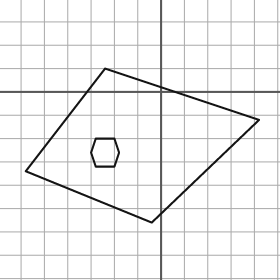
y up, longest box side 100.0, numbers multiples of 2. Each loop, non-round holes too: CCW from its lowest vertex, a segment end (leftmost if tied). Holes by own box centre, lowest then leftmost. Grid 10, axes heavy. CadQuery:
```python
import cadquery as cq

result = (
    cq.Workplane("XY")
    .moveTo(-4.0, -56.0)
    .lineTo(42.0, -12.0)
    .lineTo(-24.0, 10.0)
    .lineTo(-58.0, -34.0)
    .close()
    .moveTo(-28.0, -32.0)
    .lineTo(-20.0, -32.0)
    .lineTo(-18.0, -26.0)
    .lineTo(-20.0, -20.0)
    .lineTo(-28.0, -20.0)
    .lineTo(-30.0, -26.0)
    .close()
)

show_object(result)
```